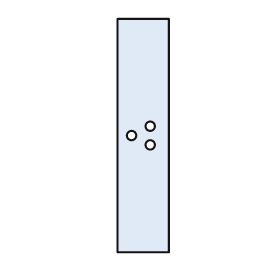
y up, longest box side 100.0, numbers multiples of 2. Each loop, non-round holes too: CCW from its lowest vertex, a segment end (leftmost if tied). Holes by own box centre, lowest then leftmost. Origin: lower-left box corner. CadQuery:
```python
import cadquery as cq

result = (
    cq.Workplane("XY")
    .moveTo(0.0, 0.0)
    .lineTo(22.0, 0.0)
    .lineTo(22.0, 100.0)
    .lineTo(0.0, 100.0)
    .close()
    .moveTo(14.0, 46.0)
    .circle(2.0)
    .moveTo(6.0, 50.0)
    .circle(2.0)
    .moveTo(14.0, 54.0)
    .circle(2.0)
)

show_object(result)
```